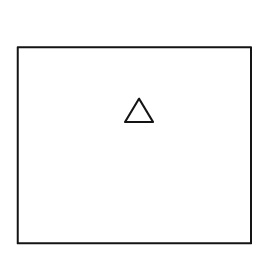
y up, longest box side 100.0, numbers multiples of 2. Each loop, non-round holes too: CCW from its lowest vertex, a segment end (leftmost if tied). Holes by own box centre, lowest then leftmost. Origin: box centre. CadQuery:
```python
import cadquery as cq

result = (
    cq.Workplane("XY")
    .moveTo(-50.0, -42.0)
    .lineTo(50.0, -42.0)
    .lineTo(50.0, 42.0)
    .lineTo(-50.0, 42.0)
    .close()
    .moveTo(-4.0, 10.0)
    .lineTo(8.0, 10.0)
    .lineTo(2.0, 20.0)
    .close()
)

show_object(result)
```